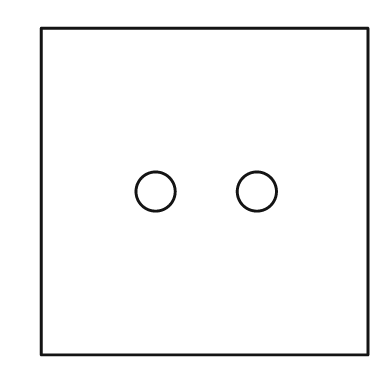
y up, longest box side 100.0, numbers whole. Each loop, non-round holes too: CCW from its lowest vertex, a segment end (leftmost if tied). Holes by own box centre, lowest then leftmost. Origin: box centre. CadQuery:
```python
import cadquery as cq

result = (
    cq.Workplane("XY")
    .moveTo(-50.0, -50.0)
    .lineTo(50.0, -50.0)
    .lineTo(50.0, 50.0)
    .lineTo(-50.0, 50.0)
    .close()
    .moveTo(-15.0, 0.0)
    .circle(6.0)
    .moveTo(16.0, 0.0)
    .circle(6.0)
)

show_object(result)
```